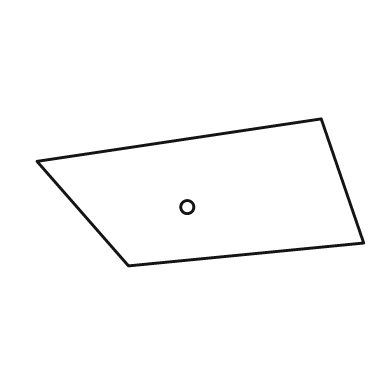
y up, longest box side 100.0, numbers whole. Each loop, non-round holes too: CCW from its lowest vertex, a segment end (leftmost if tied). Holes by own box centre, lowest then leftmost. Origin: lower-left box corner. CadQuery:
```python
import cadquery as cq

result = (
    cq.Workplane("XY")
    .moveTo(28.0, 0.0)
    .lineTo(100.0, 7.0)
    .lineTo(87.0, 45.0)
    .lineTo(0.0, 32.0)
    .close()
    .moveTo(46.0, 18.0)
    .circle(2.0)
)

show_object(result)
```